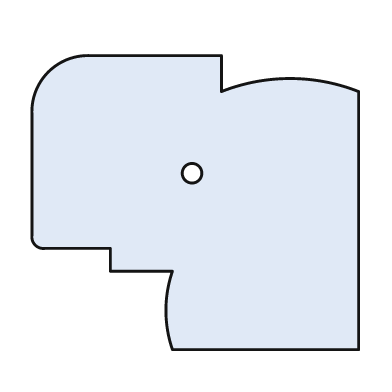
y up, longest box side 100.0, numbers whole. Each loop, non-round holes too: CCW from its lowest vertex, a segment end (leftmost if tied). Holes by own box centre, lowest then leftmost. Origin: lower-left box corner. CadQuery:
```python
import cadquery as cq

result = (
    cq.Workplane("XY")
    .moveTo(43.0, 0.0)
    .lineTo(100.0, 0.0)
    .lineTo(100.0, 79.0)
    .threePointArc((79.0, 83.0), (58.0, 79.0))
    .lineTo(58.0, 90.0)
    .lineTo(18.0, 90.0)
    .threePointArc((5.0, 85.0), (0.0, 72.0))
    .lineTo(0.0, 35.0)
    .threePointArc((1.0, 32.0), (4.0, 31.0))
    .lineTo(24.0, 31.0)
    .lineTo(24.0, 24.0)
    .lineTo(43.0, 24.0)
    .threePointArc((41.0, 12.0), (43.0, 0.0))
    .close()
    .moveTo(49.0, 54.0)
    .circle(3.0)
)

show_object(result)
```